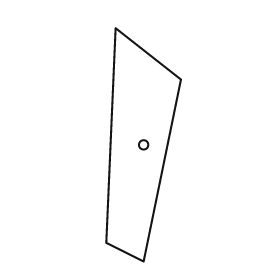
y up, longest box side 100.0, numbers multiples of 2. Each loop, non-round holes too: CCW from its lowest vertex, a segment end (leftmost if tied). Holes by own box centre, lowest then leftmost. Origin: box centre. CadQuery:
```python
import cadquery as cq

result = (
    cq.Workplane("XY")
    .moveTo(0.0, -50.0)
    .lineTo(16.0, 28.0)
    .lineTo(-12.0, 50.0)
    .lineTo(-16.0, -42.0)
    .close()
    .moveTo(0.0, 0.0)
    .circle(2.0)
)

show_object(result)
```